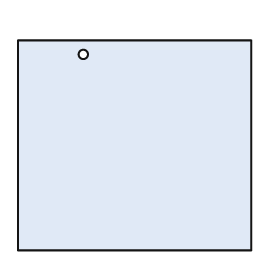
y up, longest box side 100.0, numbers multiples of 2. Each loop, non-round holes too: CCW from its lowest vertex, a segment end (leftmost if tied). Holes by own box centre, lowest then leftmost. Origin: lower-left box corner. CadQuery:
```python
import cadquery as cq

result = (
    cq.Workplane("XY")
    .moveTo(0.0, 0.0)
    .lineTo(100.0, 0.0)
    .lineTo(100.0, 90.0)
    .lineTo(0.0, 90.0)
    .close()
    .moveTo(28.0, 84.0)
    .circle(2.0)
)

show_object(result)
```